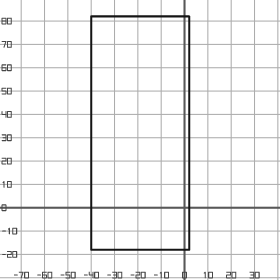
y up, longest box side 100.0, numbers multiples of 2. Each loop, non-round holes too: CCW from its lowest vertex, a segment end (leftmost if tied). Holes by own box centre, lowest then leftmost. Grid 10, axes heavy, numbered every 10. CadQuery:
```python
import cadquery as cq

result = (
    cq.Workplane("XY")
    .moveTo(-40.0, -18.0)
    .lineTo(2.0, -18.0)
    .lineTo(2.0, 82.0)
    .lineTo(-40.0, 82.0)
    .close()
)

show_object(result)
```